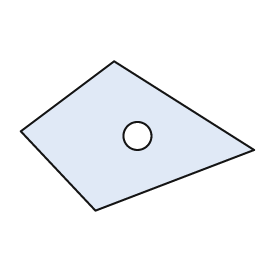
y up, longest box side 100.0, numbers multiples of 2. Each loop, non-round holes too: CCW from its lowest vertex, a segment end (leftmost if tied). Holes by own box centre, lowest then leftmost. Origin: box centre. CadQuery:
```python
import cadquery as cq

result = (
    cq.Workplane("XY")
    .moveTo(-18.0, -32.0)
    .lineTo(50.0, -6.0)
    .lineTo(-10.0, 32.0)
    .lineTo(-50.0, 2.0)
    .close()
    .moveTo(0.0, 0.0)
    .circle(6.0)
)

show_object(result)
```